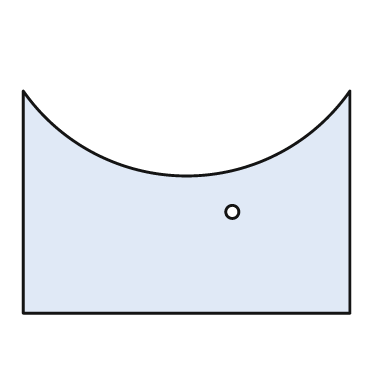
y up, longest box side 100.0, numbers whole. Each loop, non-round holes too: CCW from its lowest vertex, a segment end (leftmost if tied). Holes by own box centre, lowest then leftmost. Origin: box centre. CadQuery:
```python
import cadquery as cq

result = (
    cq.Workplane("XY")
    .moveTo(-50.0, -34.0)
    .lineTo(50.0, -34.0)
    .lineTo(50.0, 34.0)
    .threePointArc((0.0, 8.0), (-50.0, 34.0))
    .close()
    .moveTo(14.0, -3.0)
    .circle(2.0)
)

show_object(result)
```